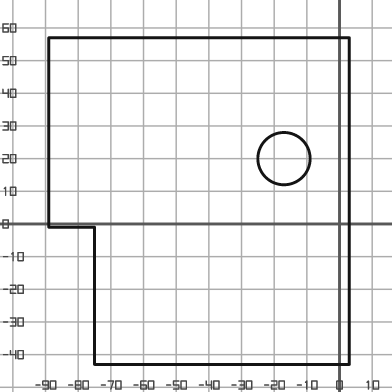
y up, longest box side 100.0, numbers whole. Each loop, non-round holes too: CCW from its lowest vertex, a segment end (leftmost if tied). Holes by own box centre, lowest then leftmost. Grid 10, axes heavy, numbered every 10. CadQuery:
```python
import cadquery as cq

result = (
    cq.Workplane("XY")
    .moveTo(-75.0, -43.0)
    .lineTo(3.0, -43.0)
    .lineTo(3.0, 57.0)
    .lineTo(-89.0, 57.0)
    .lineTo(-89.0, -1.0)
    .lineTo(-75.0, -1.0)
    .close()
    .moveTo(-17.0, 20.0)
    .circle(8.0)
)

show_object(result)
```